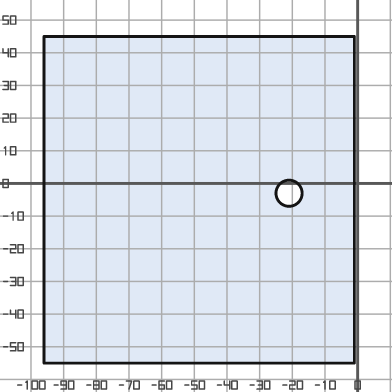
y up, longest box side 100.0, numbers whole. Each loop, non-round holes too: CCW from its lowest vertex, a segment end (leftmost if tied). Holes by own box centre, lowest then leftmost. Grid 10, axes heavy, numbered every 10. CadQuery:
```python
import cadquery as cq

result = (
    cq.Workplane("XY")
    .moveTo(-96.0, -55.0)
    .lineTo(-1.0, -55.0)
    .lineTo(-1.0, 45.0)
    .lineTo(-96.0, 45.0)
    .close()
    .moveTo(-21.0, -3.0)
    .circle(4.0)
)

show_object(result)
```